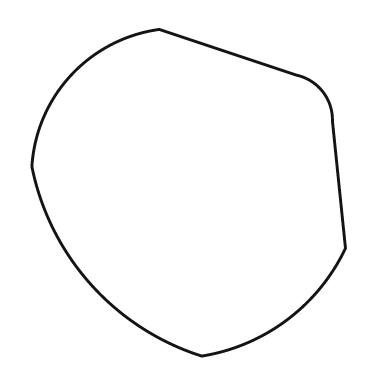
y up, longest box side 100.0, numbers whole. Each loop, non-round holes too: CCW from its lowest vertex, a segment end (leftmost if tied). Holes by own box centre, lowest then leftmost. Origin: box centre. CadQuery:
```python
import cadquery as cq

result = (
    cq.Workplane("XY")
    .moveTo(4.0, -50.0)
    .threePointArc((30.0, -39.0), (48.0, -17.0))
    .lineTo(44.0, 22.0)
    .threePointArc((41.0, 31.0), (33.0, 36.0))
    .lineTo(-9.0, 50.0)
    .threePointArc((-36.0, 36.0), (-48.0, 8.0))
    .threePointArc((-30.0, -28.0), (4.0, -50.0))
    .close()
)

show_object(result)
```